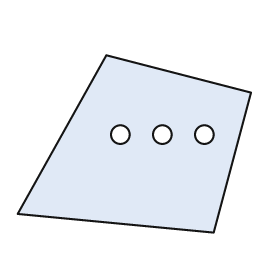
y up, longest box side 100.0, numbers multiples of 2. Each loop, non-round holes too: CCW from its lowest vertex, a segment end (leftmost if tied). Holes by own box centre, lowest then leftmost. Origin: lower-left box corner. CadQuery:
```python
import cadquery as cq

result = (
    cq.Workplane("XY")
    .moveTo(84.0, 0.0)
    .lineTo(100.0, 60.0)
    .lineTo(38.0, 76.0)
    .lineTo(0.0, 8.0)
    .close()
    .moveTo(44.0, 42.0)
    .circle(4.0)
    .moveTo(62.0, 42.0)
    .circle(4.0)
    .moveTo(80.0, 42.0)
    .circle(4.0)
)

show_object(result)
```